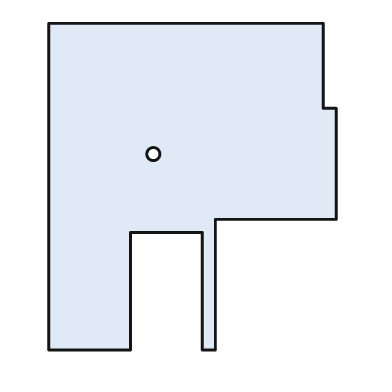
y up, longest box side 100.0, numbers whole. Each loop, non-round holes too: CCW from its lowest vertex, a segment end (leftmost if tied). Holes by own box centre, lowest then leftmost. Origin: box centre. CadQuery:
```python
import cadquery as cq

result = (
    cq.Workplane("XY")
    .moveTo(-44.0, -50.0)
    .lineTo(-19.0, -50.0)
    .lineTo(-19.0, -14.0)
    .lineTo(3.0, -14.0)
    .lineTo(3.0, -50.0)
    .lineTo(7.0, -50.0)
    .lineTo(7.0, -10.0)
    .lineTo(44.0, -10.0)
    .lineTo(44.0, 24.0)
    .lineTo(40.0, 24.0)
    .lineTo(40.0, 50.0)
    .lineTo(-44.0, 50.0)
    .close()
    .moveTo(-12.0, 10.0)
    .circle(2.0)
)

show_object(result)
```